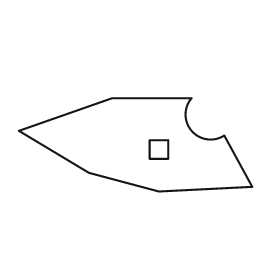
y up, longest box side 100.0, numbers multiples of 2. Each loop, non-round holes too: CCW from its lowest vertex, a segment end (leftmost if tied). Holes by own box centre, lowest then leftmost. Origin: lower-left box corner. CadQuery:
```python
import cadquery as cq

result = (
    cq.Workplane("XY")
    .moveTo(60.0, 0.0)
    .lineTo(100.0, 2.0)
    .lineTo(88.0, 24.0)
    .threePointArc((74.0, 26.0), (74.0, 40.0))
    .lineTo(40.0, 40.0)
    .lineTo(0.0, 26.0)
    .lineTo(30.0, 8.0)
    .close()
    .moveTo(56.0, 14.0)
    .lineTo(64.0, 14.0)
    .lineTo(64.0, 22.0)
    .lineTo(56.0, 22.0)
    .close()
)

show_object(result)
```